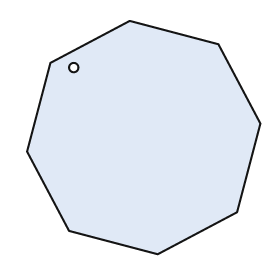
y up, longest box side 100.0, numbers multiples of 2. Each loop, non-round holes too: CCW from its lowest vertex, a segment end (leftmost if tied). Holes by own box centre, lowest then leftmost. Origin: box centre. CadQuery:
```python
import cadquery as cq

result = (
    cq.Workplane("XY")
    .moveTo(6.0, -50.0)
    .lineTo(40.0, -32.0)
    .lineTo(50.0, 6.0)
    .lineTo(32.0, 40.0)
    .lineTo(-6.0, 50.0)
    .lineTo(-40.0, 32.0)
    .lineTo(-50.0, -6.0)
    .lineTo(-32.0, -40.0)
    .close()
    .moveTo(-30.0, 30.0)
    .circle(2.0)
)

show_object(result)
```